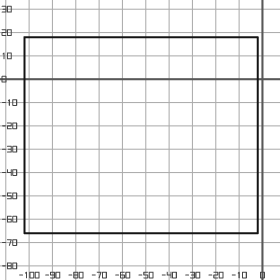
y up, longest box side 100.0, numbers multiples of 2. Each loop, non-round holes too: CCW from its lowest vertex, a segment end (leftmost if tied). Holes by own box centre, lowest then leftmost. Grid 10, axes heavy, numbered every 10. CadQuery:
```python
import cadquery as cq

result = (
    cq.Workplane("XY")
    .moveTo(-102.0, -66.0)
    .lineTo(-2.0, -66.0)
    .lineTo(-2.0, 18.0)
    .lineTo(-102.0, 18.0)
    .close()
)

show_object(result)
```